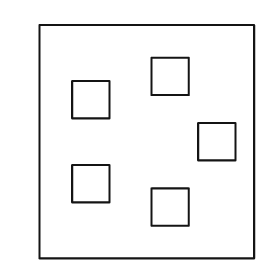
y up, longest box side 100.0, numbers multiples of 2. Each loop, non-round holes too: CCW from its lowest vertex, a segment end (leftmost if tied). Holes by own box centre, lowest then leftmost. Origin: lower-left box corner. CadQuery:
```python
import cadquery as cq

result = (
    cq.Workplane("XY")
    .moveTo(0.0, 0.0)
    .lineTo(92.0, 0.0)
    .lineTo(92.0, 100.0)
    .lineTo(0.0, 100.0)
    .close()
    .moveTo(48.0, 14.0)
    .lineTo(64.0, 14.0)
    .lineTo(64.0, 30.0)
    .lineTo(48.0, 30.0)
    .close()
    .moveTo(14.0, 24.0)
    .lineTo(30.0, 24.0)
    .lineTo(30.0, 40.0)
    .lineTo(14.0, 40.0)
    .close()
    .moveTo(68.0, 42.0)
    .lineTo(84.0, 42.0)
    .lineTo(84.0, 58.0)
    .lineTo(68.0, 58.0)
    .close()
    .moveTo(14.0, 60.0)
    .lineTo(30.0, 60.0)
    .lineTo(30.0, 76.0)
    .lineTo(14.0, 76.0)
    .close()
    .moveTo(48.0, 70.0)
    .lineTo(64.0, 70.0)
    .lineTo(64.0, 86.0)
    .lineTo(48.0, 86.0)
    .close()
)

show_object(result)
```